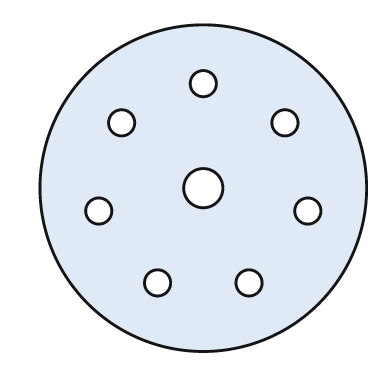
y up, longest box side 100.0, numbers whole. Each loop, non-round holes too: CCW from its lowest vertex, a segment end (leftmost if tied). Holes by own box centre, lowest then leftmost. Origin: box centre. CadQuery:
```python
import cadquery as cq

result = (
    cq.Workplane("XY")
    .moveTo(0.0, 0.0)
    .circle(50.0)
    .moveTo(-14.0, -29.0)
    .circle(4.0)
    .moveTo(14.0, -29.0)
    .circle(4.0)
    .moveTo(-32.0, -7.0)
    .circle(4.0)
    .moveTo(32.0, -7.0)
    .circle(4.0)
    .moveTo(0.0, 0.0)
    .circle(6.0)
    .moveTo(-25.0, 20.0)
    .circle(4.0)
    .moveTo(25.0, 20.0)
    .circle(4.0)
    .moveTo(0.0, 32.0)
    .circle(4.0)
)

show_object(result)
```